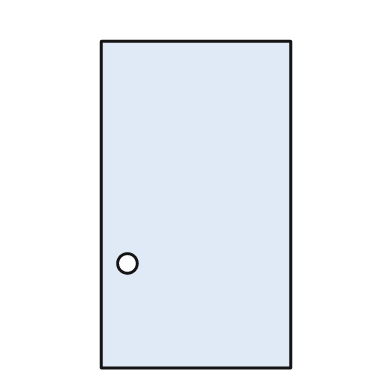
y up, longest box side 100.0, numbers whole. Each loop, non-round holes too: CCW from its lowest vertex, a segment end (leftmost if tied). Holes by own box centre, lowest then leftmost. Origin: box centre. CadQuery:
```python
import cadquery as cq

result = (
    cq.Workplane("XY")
    .moveTo(-29.0, -50.0)
    .lineTo(29.0, -50.0)
    .lineTo(29.0, 50.0)
    .lineTo(-29.0, 50.0)
    .close()
    .moveTo(-21.0, -18.0)
    .circle(3.0)
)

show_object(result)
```